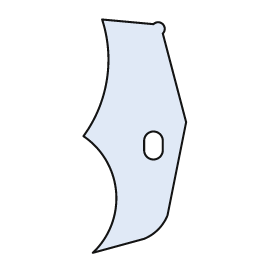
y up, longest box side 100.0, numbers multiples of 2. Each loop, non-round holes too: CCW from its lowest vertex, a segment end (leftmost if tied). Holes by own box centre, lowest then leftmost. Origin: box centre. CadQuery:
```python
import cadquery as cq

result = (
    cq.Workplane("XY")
    .moveTo(-18.0, -50.0)
    .lineTo(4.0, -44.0)
    .threePointArc((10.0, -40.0), (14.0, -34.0))
    .lineTo(22.0, 6.0)
    .lineTo(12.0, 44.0)
    .threePointArc((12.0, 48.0), (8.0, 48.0))
    .lineTo(-14.0, 50.0)
    .threePointArc((-12.0, 24.0), (-22.0, 0.0))
    .threePointArc((-8.0, -24.0), (-18.0, -50.0))
    .close()
    .moveTo(4.0, -6.0)
    .threePointArc((8.0, -10.0), (12.0, -6.0))
    .lineTo(12.0, -2.0)
    .threePointArc((8.0, 2.0), (4.0, -2.0))
    .close()
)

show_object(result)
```